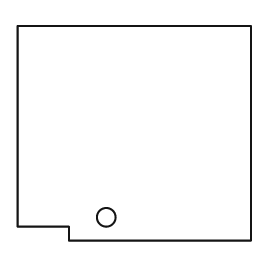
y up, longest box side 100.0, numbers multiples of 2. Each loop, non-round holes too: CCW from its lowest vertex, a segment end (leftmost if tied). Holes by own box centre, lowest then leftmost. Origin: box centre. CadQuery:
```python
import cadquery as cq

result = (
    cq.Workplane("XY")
    .moveTo(-28.0, -46.0)
    .lineTo(50.0, -46.0)
    .lineTo(50.0, 46.0)
    .lineTo(-50.0, 46.0)
    .lineTo(-50.0, -40.0)
    .lineTo(-28.0, -40.0)
    .close()
    .moveTo(-12.0, -36.0)
    .circle(4.0)
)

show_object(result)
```